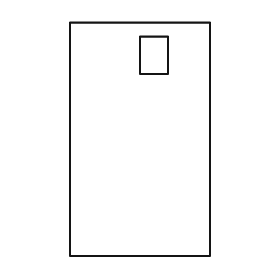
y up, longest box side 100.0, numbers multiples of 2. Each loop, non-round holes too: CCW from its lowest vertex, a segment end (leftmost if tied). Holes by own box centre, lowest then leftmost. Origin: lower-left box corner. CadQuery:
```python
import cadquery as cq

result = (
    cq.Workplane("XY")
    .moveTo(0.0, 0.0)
    .lineTo(60.0, 0.0)
    .lineTo(60.0, 100.0)
    .lineTo(0.0, 100.0)
    .close()
    .moveTo(30.0, 78.0)
    .lineTo(42.0, 78.0)
    .lineTo(42.0, 94.0)
    .lineTo(30.0, 94.0)
    .close()
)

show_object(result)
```